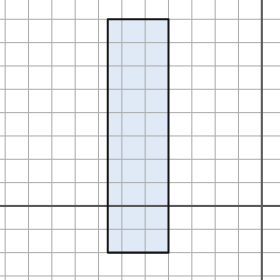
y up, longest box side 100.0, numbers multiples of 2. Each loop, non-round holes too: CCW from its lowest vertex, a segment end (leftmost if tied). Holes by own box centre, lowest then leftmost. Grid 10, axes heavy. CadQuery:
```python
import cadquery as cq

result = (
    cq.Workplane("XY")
    .moveTo(-66.0, -20.0)
    .lineTo(-40.0, -20.0)
    .lineTo(-40.0, 80.0)
    .lineTo(-66.0, 80.0)
    .close()
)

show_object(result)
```